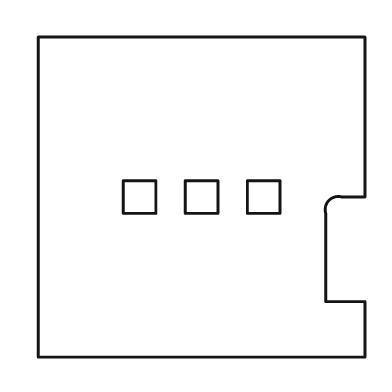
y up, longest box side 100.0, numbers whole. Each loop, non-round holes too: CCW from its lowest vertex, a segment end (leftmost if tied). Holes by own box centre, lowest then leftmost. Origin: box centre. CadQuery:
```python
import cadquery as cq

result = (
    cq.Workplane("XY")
    .moveTo(-50.0, -49.0)
    .lineTo(50.0, -49.0)
    .lineTo(50.0, -32.0)
    .lineTo(38.0, -32.0)
    .lineTo(38.0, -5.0)
    .threePointArc((39.0, -1.0), (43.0, 0.0))
    .lineTo(50.0, 0.0)
    .lineTo(50.0, 49.0)
    .lineTo(-50.0, 49.0)
    .close()
    .moveTo(-24.0, -5.0)
    .lineTo(-14.0, -5.0)
    .lineTo(-14.0, 5.0)
    .lineTo(-24.0, 5.0)
    .close()
    .moveTo(-5.0, -5.0)
    .lineTo(5.0, -5.0)
    .lineTo(5.0, 5.0)
    .lineTo(-5.0, 5.0)
    .close()
    .moveTo(14.0, -5.0)
    .lineTo(24.0, -5.0)
    .lineTo(24.0, 5.0)
    .lineTo(14.0, 5.0)
    .close()
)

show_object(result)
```